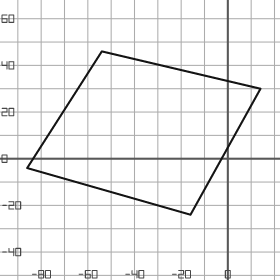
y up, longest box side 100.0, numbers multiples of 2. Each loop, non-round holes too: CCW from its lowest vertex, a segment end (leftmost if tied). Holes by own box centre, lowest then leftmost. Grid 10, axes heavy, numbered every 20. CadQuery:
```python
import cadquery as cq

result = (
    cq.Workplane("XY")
    .moveTo(-16.0, -24.0)
    .lineTo(14.0, 30.0)
    .lineTo(-54.0, 46.0)
    .lineTo(-86.0, -4.0)
    .close()
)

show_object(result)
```